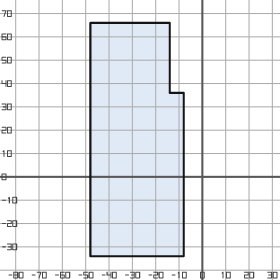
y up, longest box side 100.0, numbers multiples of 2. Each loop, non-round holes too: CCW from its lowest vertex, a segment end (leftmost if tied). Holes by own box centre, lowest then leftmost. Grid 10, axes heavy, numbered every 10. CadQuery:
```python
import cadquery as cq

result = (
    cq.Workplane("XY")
    .moveTo(-48.0, -34.0)
    .lineTo(-8.0, -34.0)
    .lineTo(-8.0, 36.0)
    .lineTo(-14.0, 36.0)
    .lineTo(-14.0, 66.0)
    .lineTo(-48.0, 66.0)
    .close()
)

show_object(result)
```